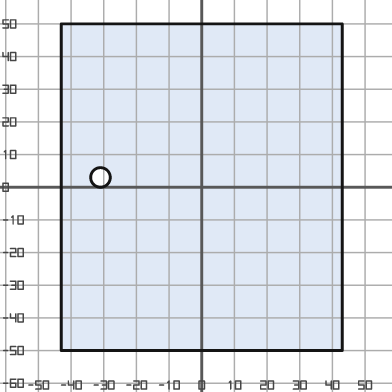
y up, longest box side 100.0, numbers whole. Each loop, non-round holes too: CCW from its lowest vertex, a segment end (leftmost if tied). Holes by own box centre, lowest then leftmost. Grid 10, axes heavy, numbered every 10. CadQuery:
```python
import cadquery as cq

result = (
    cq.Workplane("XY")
    .moveTo(-43.0, -50.0)
    .lineTo(43.0, -50.0)
    .lineTo(43.0, 50.0)
    .lineTo(-43.0, 50.0)
    .close()
    .moveTo(-31.0, 3.0)
    .circle(3.0)
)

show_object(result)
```